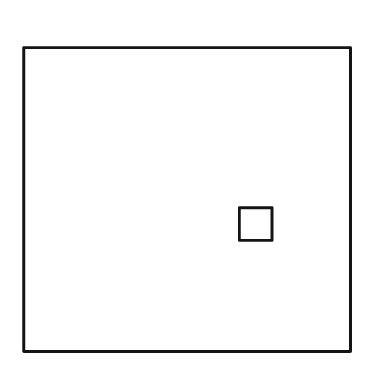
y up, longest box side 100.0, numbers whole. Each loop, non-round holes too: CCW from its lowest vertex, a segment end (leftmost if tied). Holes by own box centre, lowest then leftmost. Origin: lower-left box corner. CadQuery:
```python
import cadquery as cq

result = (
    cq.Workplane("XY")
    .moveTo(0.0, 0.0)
    .lineTo(100.0, 0.0)
    .lineTo(100.0, 93.0)
    .lineTo(0.0, 93.0)
    .close()
    .moveTo(66.0, 34.0)
    .lineTo(76.0, 34.0)
    .lineTo(76.0, 44.0)
    .lineTo(66.0, 44.0)
    .close()
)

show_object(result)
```